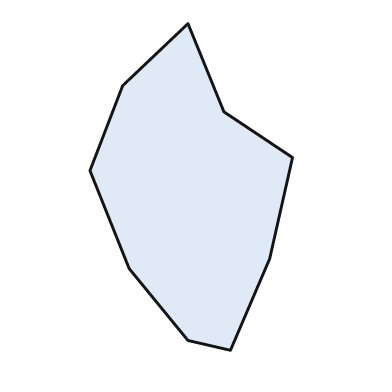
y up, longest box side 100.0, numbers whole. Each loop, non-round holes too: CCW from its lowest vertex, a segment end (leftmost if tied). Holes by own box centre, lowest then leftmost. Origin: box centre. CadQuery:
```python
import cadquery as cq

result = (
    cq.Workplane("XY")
    .moveTo(12.0, -50.0)
    .lineTo(24.0, -22.0)
    .lineTo(31.0, 9.0)
    .lineTo(10.0, 23.0)
    .lineTo(-1.0, 50.0)
    .lineTo(-21.0, 31.0)
    .lineTo(-31.0, 5.0)
    .lineTo(-19.0, -25.0)
    .lineTo(-1.0, -47.0)
    .close()
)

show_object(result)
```